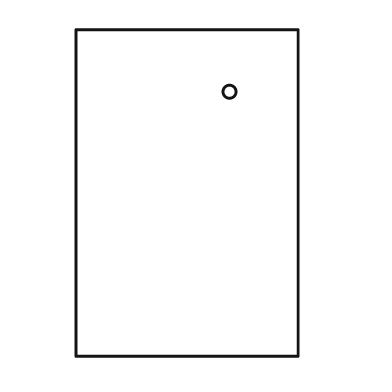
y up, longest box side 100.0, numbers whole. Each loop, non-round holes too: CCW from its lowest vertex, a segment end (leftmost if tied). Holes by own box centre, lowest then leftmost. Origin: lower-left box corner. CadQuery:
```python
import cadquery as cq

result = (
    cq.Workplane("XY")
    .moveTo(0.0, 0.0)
    .lineTo(68.0, 0.0)
    .lineTo(68.0, 100.0)
    .lineTo(0.0, 100.0)
    .close()
    .moveTo(47.0, 81.0)
    .circle(2.0)
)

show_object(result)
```